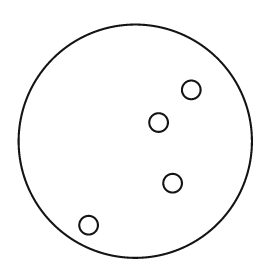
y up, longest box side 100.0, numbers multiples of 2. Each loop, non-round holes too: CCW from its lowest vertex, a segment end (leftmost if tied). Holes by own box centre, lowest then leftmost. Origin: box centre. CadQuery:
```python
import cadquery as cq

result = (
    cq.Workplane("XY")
    .moveTo(0.0, 0.0)
    .circle(50.0)
    .moveTo(-20.0, -36.0)
    .circle(4.0)
    .moveTo(16.0, -18.0)
    .circle(4.0)
    .moveTo(10.0, 8.0)
    .circle(4.0)
    .moveTo(24.0, 22.0)
    .circle(4.0)
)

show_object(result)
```